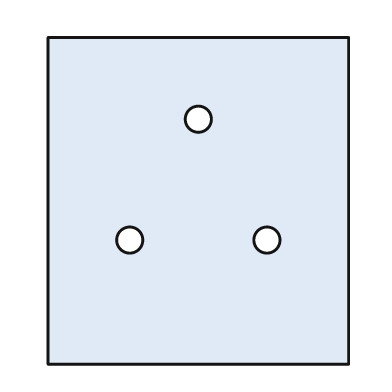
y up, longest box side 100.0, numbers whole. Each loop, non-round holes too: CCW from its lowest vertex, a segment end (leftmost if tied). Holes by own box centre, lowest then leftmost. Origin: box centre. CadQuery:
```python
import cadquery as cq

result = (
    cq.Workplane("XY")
    .moveTo(-46.0, -50.0)
    .lineTo(46.0, -50.0)
    .lineTo(46.0, 50.0)
    .lineTo(-46.0, 50.0)
    .close()
    .moveTo(-21.0, -12.0)
    .circle(4.0)
    .moveTo(21.0, -12.0)
    .circle(4.0)
    .moveTo(0.0, 25.0)
    .circle(4.0)
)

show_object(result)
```